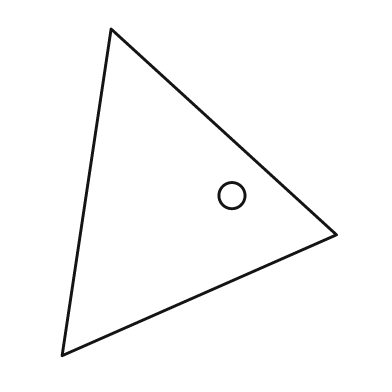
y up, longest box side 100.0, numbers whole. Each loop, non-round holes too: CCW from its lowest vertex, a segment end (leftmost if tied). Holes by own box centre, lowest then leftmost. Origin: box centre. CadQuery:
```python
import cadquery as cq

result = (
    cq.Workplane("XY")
    .moveTo(-42.0, -50.0)
    .lineTo(42.0, -13.0)
    .lineTo(-27.0, 50.0)
    .close()
    .moveTo(10.0, -1.0)
    .circle(4.0)
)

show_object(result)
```